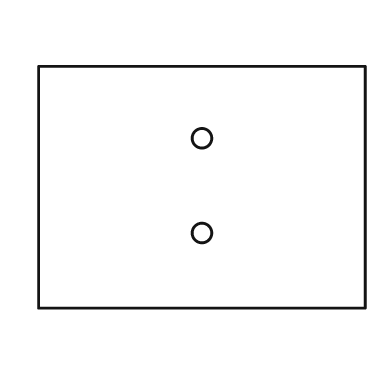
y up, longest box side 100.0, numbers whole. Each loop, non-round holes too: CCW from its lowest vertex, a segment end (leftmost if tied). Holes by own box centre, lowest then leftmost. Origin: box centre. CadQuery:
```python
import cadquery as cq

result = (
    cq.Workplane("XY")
    .moveTo(-50.0, -37.0)
    .lineTo(50.0, -37.0)
    .lineTo(50.0, 37.0)
    .lineTo(-50.0, 37.0)
    .close()
    .moveTo(0.0, -14.0)
    .circle(3.0)
    .moveTo(0.0, 15.0)
    .circle(3.0)
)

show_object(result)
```